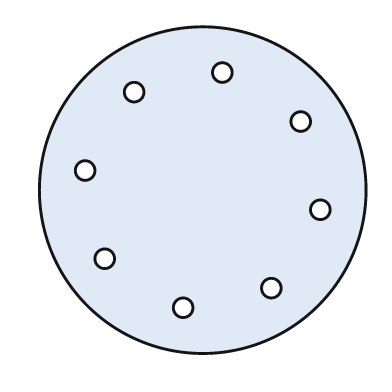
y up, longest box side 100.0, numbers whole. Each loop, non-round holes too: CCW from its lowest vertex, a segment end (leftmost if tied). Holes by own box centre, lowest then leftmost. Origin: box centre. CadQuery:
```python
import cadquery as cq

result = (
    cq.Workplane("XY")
    .moveTo(0.0, 0.0)
    .circle(50.0)
    .moveTo(-6.0, -36.0)
    .circle(3.0)
    .moveTo(21.0, -30.0)
    .circle(3.0)
    .moveTo(-30.0, -21.0)
    .circle(3.0)
    .moveTo(36.0, -6.0)
    .circle(3.0)
    .moveTo(-36.0, 6.0)
    .circle(3.0)
    .moveTo(30.0, 21.0)
    .circle(3.0)
    .moveTo(-21.0, 30.0)
    .circle(3.0)
    .moveTo(6.0, 36.0)
    .circle(3.0)
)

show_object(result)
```